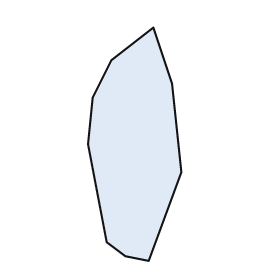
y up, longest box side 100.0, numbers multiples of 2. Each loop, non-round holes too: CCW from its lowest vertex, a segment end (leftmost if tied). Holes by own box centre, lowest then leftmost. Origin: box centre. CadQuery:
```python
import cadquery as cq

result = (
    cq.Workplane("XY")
    .moveTo(6.0, -50.0)
    .lineTo(20.0, -12.0)
    .lineTo(16.0, 26.0)
    .lineTo(8.0, 50.0)
    .lineTo(-10.0, 36.0)
    .lineTo(-18.0, 20.0)
    .lineTo(-20.0, 0.0)
    .lineTo(-12.0, -42.0)
    .lineTo(-4.0, -48.0)
    .close()
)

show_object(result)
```